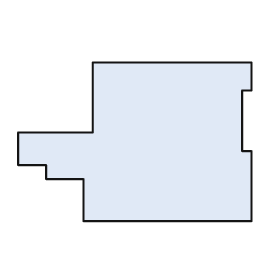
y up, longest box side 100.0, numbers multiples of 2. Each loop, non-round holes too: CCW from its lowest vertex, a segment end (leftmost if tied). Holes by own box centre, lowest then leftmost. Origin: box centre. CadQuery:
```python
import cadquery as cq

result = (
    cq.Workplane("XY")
    .moveTo(-22.0, -34.0)
    .lineTo(50.0, -34.0)
    .lineTo(50.0, -4.0)
    .lineTo(46.0, -4.0)
    .lineTo(46.0, 22.0)
    .lineTo(50.0, 22.0)
    .lineTo(50.0, 34.0)
    .lineTo(-18.0, 34.0)
    .lineTo(-18.0, 4.0)
    .lineTo(-50.0, 4.0)
    .lineTo(-50.0, -10.0)
    .lineTo(-38.0, -10.0)
    .lineTo(-38.0, -16.0)
    .lineTo(-22.0, -16.0)
    .close()
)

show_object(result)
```